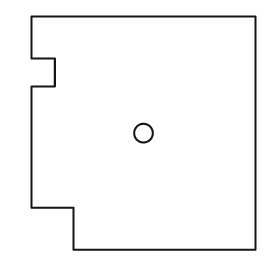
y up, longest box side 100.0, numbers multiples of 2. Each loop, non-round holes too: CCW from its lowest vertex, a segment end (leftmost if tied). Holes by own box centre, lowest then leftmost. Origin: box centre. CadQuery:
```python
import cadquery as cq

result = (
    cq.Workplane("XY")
    .moveTo(-30.0, -50.0)
    .lineTo(48.0, -50.0)
    .lineTo(48.0, 50.0)
    .lineTo(-48.0, 50.0)
    .lineTo(-48.0, 32.0)
    .lineTo(-38.0, 32.0)
    .lineTo(-38.0, 20.0)
    .lineTo(-48.0, 20.0)
    .lineTo(-48.0, -32.0)
    .lineTo(-30.0, -32.0)
    .close()
    .moveTo(0.0, 0.0)
    .circle(4.0)
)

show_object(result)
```